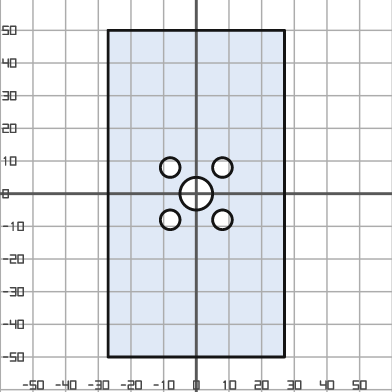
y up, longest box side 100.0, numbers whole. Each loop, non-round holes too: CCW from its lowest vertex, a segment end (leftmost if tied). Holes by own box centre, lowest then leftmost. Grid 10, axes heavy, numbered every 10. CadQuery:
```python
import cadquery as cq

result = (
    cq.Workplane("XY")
    .moveTo(-27.0, -50.0)
    .lineTo(27.0, -50.0)
    .lineTo(27.0, 50.0)
    .lineTo(-27.0, 50.0)
    .close()
    .moveTo(-8.0, -8.0)
    .circle(3.0)
    .moveTo(8.0, -8.0)
    .circle(3.0)
    .moveTo(0.0, 0.0)
    .circle(5.0)
    .moveTo(-8.0, 8.0)
    .circle(3.0)
    .moveTo(8.0, 8.0)
    .circle(3.0)
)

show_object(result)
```